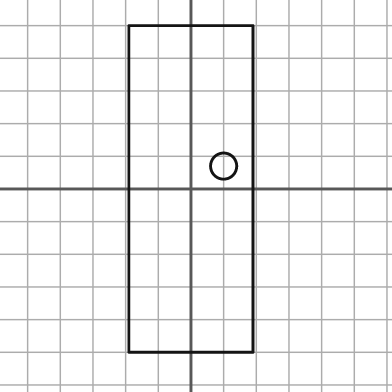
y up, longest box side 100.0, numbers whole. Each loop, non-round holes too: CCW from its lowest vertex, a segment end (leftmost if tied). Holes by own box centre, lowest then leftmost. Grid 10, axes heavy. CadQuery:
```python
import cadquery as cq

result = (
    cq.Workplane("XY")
    .moveTo(-19.0, -50.0)
    .lineTo(19.0, -50.0)
    .lineTo(19.0, 50.0)
    .lineTo(-19.0, 50.0)
    .close()
    .moveTo(10.0, 7.0)
    .circle(4.0)
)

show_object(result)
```